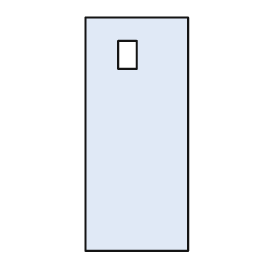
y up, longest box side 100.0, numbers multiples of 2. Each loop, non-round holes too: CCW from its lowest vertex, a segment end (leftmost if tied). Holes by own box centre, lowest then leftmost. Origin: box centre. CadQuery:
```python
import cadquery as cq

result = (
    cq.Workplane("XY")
    .moveTo(-22.0, -50.0)
    .lineTo(22.0, -50.0)
    .lineTo(22.0, 50.0)
    .lineTo(-22.0, 50.0)
    .close()
    .moveTo(-8.0, 28.0)
    .lineTo(0.0, 28.0)
    .lineTo(0.0, 40.0)
    .lineTo(-8.0, 40.0)
    .close()
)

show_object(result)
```